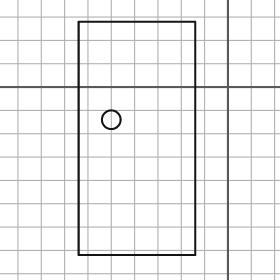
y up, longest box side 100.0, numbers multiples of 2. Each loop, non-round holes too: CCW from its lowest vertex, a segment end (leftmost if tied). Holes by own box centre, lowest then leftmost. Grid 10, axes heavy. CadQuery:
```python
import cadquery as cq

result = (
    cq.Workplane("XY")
    .moveTo(-64.0, -72.0)
    .lineTo(-14.0, -72.0)
    .lineTo(-14.0, 28.0)
    .lineTo(-64.0, 28.0)
    .close()
    .moveTo(-50.0, -14.0)
    .circle(4.0)
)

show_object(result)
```